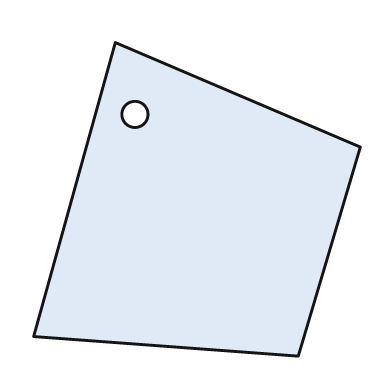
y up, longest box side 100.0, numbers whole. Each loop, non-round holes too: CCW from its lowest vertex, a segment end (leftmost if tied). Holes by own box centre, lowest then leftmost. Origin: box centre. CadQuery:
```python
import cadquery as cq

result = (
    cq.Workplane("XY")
    .moveTo(31.0, -48.0)
    .lineTo(50.0, 16.0)
    .lineTo(-25.0, 48.0)
    .lineTo(-50.0, -42.0)
    .close()
    .moveTo(-19.0, 26.0)
    .circle(4.0)
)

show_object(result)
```